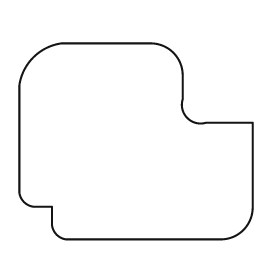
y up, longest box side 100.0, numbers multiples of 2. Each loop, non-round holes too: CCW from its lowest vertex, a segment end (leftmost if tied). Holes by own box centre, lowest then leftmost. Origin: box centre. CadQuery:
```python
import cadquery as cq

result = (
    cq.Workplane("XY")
    .moveTo(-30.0, -42.0)
    .lineTo(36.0, -42.0)
    .threePointArc((46.0, -38.0), (50.0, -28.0))
    .lineTo(50.0, 8.0)
    .lineTo(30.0, 8.0)
    .threePointArc((22.0, 10.0), (20.0, 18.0))
    .lineTo(20.0, 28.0)
    .threePointArc((16.0, 38.0), (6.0, 42.0))
    .lineTo(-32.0, 42.0)
    .threePointArc((-44.0, 36.0), (-50.0, 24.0))
    .lineTo(-50.0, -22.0)
    .threePointArc((-48.0, -26.0), (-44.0, -28.0))
    .lineTo(-36.0, -28.0)
    .lineTo(-36.0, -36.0)
    .threePointArc((-34.0, -40.0), (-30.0, -42.0))
    .close()
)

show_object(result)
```